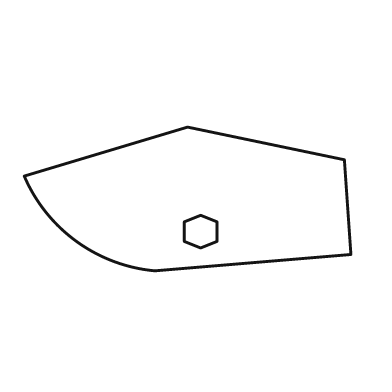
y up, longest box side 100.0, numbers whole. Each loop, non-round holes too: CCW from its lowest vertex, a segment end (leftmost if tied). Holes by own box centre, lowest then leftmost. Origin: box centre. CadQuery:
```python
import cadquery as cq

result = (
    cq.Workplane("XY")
    .moveTo(-10.0, -22.0)
    .lineTo(50.0, -17.0)
    .lineTo(48.0, 12.0)
    .lineTo(0.0, 22.0)
    .lineTo(-50.0, 7.0)
    .threePointArc((-34.0, -13.0), (-10.0, -22.0))
    .close()
    .moveTo(4.0, -15.0)
    .lineTo(9.0, -13.0)
    .lineTo(9.0, -7.0)
    .lineTo(4.0, -5.0)
    .lineTo(-1.0, -7.0)
    .lineTo(-1.0, -13.0)
    .close()
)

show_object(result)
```